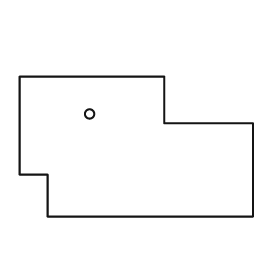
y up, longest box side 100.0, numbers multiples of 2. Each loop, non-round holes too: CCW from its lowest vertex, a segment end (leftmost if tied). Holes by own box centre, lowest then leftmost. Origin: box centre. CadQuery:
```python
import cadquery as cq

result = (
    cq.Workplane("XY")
    .moveTo(-38.0, -30.0)
    .lineTo(50.0, -30.0)
    .lineTo(50.0, 10.0)
    .lineTo(12.0, 10.0)
    .lineTo(12.0, 30.0)
    .lineTo(-50.0, 30.0)
    .lineTo(-50.0, -12.0)
    .lineTo(-38.0, -12.0)
    .close()
    .moveTo(-20.0, 14.0)
    .circle(2.0)
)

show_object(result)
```